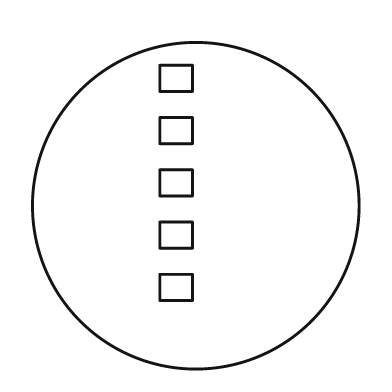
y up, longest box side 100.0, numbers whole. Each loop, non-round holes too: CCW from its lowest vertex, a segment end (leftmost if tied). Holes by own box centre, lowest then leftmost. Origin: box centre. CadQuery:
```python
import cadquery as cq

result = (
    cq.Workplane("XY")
    .moveTo(0.0, 0.0)
    .circle(50.0)
    .moveTo(-11.0, -29.0)
    .lineTo(-1.0, -29.0)
    .lineTo(-1.0, -21.0)
    .lineTo(-11.0, -21.0)
    .close()
    .moveTo(-11.0, -13.0)
    .lineTo(-1.0, -13.0)
    .lineTo(-1.0, -5.0)
    .lineTo(-11.0, -5.0)
    .close()
    .moveTo(-11.0, 3.0)
    .lineTo(-1.0, 3.0)
    .lineTo(-1.0, 11.0)
    .lineTo(-11.0, 11.0)
    .close()
    .moveTo(-11.0, 19.0)
    .lineTo(-1.0, 19.0)
    .lineTo(-1.0, 27.0)
    .lineTo(-11.0, 27.0)
    .close()
    .moveTo(-11.0, 35.0)
    .lineTo(-1.0, 35.0)
    .lineTo(-1.0, 43.0)
    .lineTo(-11.0, 43.0)
    .close()
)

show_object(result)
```